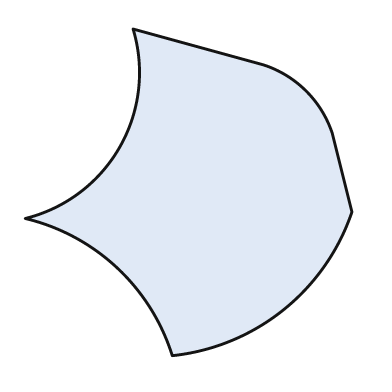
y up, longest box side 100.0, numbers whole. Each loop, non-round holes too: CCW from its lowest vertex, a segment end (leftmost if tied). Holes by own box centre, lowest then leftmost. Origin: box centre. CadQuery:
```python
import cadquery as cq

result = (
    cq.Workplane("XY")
    .moveTo(-5.0, -50.0)
    .threePointArc((29.0, -36.0), (50.0, -6.0))
    .lineTo(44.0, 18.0)
    .threePointArc((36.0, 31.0), (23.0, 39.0))
    .lineTo(-17.0, 50.0)
    .threePointArc((-21.0, 14.0), (-50.0, -8.0))
    .threePointArc((-22.0, -23.0), (-5.0, -50.0))
    .close()
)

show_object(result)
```